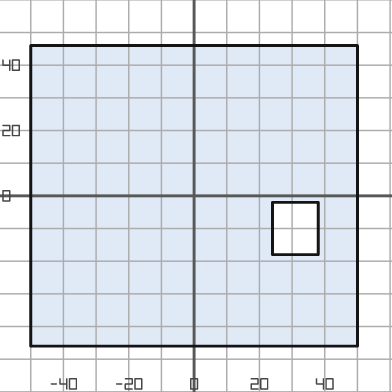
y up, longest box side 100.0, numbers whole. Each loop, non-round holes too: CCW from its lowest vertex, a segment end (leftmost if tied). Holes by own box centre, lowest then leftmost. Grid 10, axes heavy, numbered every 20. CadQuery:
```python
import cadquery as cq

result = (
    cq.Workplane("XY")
    .moveTo(-50.0, -46.0)
    .lineTo(50.0, -46.0)
    .lineTo(50.0, 46.0)
    .lineTo(-50.0, 46.0)
    .close()
    .moveTo(24.0, -18.0)
    .lineTo(38.0, -18.0)
    .lineTo(38.0, -2.0)
    .lineTo(24.0, -2.0)
    .close()
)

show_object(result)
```